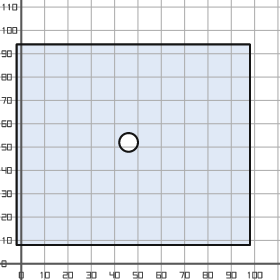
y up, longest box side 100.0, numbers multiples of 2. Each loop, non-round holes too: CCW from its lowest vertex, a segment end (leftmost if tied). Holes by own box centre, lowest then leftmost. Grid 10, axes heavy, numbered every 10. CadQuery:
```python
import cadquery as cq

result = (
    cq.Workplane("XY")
    .moveTo(-2.0, 8.0)
    .lineTo(98.0, 8.0)
    .lineTo(98.0, 94.0)
    .lineTo(-2.0, 94.0)
    .close()
    .moveTo(46.0, 52.0)
    .circle(4.0)
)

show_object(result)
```